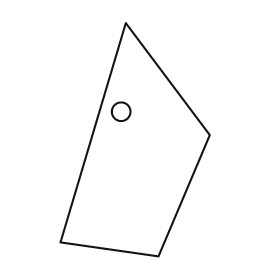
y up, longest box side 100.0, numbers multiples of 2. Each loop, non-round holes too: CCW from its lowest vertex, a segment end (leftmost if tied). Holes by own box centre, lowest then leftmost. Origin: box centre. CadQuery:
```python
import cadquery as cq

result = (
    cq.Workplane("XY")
    .moveTo(10.0, -50.0)
    .lineTo(32.0, 2.0)
    .lineTo(-4.0, 50.0)
    .lineTo(-32.0, -44.0)
    .close()
    .moveTo(-6.0, 12.0)
    .circle(4.0)
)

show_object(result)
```